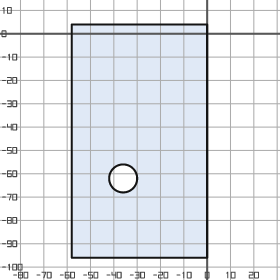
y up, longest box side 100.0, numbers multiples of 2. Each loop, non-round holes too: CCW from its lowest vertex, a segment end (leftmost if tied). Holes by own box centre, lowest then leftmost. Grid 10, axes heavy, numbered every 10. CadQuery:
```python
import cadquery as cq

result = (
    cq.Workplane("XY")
    .moveTo(-58.0, -96.0)
    .lineTo(0.0, -96.0)
    .lineTo(0.0, 4.0)
    .lineTo(-58.0, 4.0)
    .close()
    .moveTo(-36.0, -62.0)
    .circle(6.0)
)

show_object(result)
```